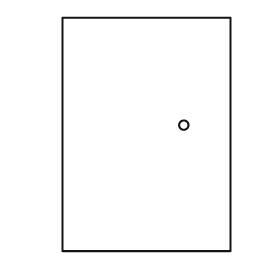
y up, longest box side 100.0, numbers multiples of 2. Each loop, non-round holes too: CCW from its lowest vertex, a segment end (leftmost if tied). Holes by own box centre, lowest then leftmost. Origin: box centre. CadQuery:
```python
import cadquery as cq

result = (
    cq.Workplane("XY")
    .moveTo(-36.0, -50.0)
    .lineTo(36.0, -50.0)
    .lineTo(36.0, 50.0)
    .lineTo(-36.0, 50.0)
    .close()
    .moveTo(16.0, 4.0)
    .circle(2.0)
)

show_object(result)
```